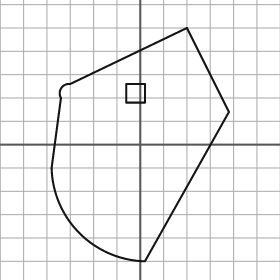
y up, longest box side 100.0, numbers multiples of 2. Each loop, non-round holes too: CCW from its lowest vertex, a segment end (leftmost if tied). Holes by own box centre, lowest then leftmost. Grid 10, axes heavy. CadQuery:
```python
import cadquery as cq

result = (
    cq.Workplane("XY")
    .moveTo(2.0, -50.0)
    .lineTo(38.0, 14.0)
    .lineTo(20.0, 50.0)
    .lineTo(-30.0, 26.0)
    .threePointArc((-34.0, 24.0), (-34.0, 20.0))
    .lineTo(-38.0, -10.0)
    .threePointArc((-26.0, -38.0), (2.0, -50.0))
    .close()
    .moveTo(-6.0, 18.0)
    .lineTo(2.0, 18.0)
    .lineTo(2.0, 26.0)
    .lineTo(-6.0, 26.0)
    .close()
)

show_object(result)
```